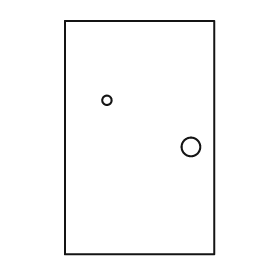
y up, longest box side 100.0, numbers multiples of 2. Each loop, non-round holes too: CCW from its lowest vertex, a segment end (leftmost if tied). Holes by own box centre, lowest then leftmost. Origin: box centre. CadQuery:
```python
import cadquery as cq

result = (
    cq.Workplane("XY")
    .moveTo(-32.0, -50.0)
    .lineTo(32.0, -50.0)
    .lineTo(32.0, 50.0)
    .lineTo(-32.0, 50.0)
    .close()
    .moveTo(22.0, -4.0)
    .circle(4.0)
    .moveTo(-14.0, 16.0)
    .circle(2.0)
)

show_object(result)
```